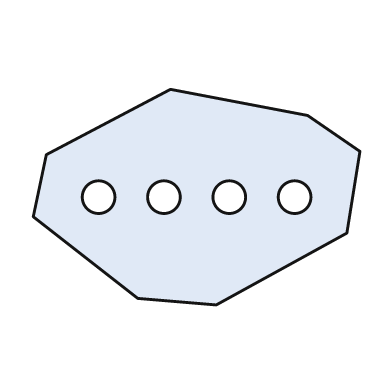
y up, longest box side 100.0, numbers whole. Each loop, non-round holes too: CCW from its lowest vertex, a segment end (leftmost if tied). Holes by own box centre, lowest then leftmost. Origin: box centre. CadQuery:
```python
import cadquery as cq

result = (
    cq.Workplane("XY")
    .moveTo(6.0, -33.0)
    .lineTo(46.0, -11.0)
    .lineTo(50.0, 14.0)
    .lineTo(34.0, 25.0)
    .lineTo(-8.0, 33.0)
    .lineTo(-46.0, 13.0)
    .lineTo(-50.0, -6.0)
    .lineTo(-18.0, -31.0)
    .close()
    .moveTo(-30.0, 0.0)
    .circle(5.0)
    .moveTo(-10.0, 0.0)
    .circle(5.0)
    .moveTo(10.0, 0.0)
    .circle(5.0)
    .moveTo(30.0, 0.0)
    .circle(5.0)
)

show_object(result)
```